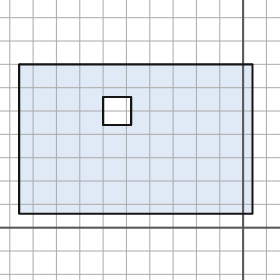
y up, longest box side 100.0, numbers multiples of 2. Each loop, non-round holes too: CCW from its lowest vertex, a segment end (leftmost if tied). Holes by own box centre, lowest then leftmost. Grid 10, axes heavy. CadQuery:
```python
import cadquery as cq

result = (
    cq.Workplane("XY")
    .moveTo(-96.0, 6.0)
    .lineTo(4.0, 6.0)
    .lineTo(4.0, 70.0)
    .lineTo(-96.0, 70.0)
    .close()
    .moveTo(-60.0, 44.0)
    .lineTo(-48.0, 44.0)
    .lineTo(-48.0, 56.0)
    .lineTo(-60.0, 56.0)
    .close()
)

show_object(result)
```